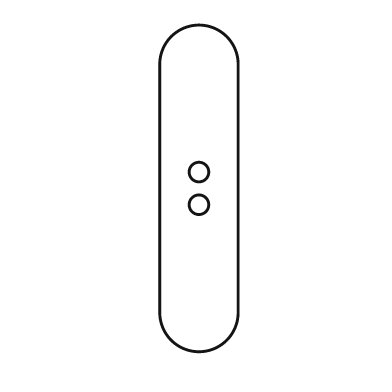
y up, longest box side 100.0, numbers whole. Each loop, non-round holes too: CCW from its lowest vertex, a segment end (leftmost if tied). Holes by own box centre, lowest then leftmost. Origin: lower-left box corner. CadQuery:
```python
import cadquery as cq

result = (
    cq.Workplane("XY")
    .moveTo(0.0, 12.0)
    .threePointArc((12.0, 0.0), (24.0, 12.0))
    .lineTo(24.0, 88.0)
    .threePointArc((12.0, 100.0), (0.0, 88.0))
    .close()
    .moveTo(12.0, 45.0)
    .circle(3.0)
    .moveTo(12.0, 55.0)
    .circle(3.0)
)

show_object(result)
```